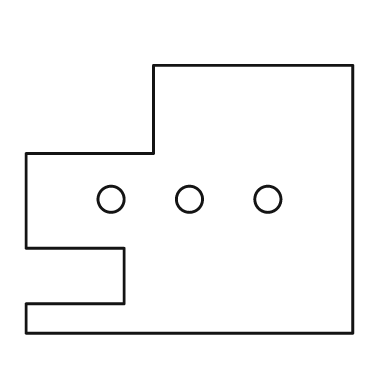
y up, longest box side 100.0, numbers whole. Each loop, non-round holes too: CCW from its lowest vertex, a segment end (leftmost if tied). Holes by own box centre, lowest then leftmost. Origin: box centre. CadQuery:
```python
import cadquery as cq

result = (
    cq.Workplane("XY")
    .moveTo(-50.0, -41.0)
    .lineTo(50.0, -41.0)
    .lineTo(50.0, 41.0)
    .lineTo(-11.0, 41.0)
    .lineTo(-11.0, 14.0)
    .lineTo(-50.0, 14.0)
    .lineTo(-50.0, -15.0)
    .lineTo(-20.0, -15.0)
    .lineTo(-20.0, -32.0)
    .lineTo(-50.0, -32.0)
    .close()
    .moveTo(-24.0, 0.0)
    .circle(4.0)
    .moveTo(0.0, 0.0)
    .circle(4.0)
    .moveTo(24.0, 0.0)
    .circle(4.0)
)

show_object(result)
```